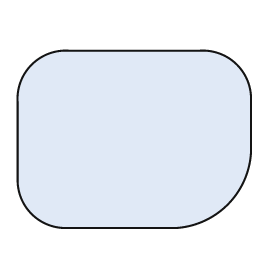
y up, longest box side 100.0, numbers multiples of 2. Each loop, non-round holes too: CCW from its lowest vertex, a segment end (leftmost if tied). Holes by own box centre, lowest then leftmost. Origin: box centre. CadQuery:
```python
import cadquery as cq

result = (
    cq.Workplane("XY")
    .moveTo(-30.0, -38.0)
    .lineTo(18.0, -38.0)
    .threePointArc((40.0, -28.0), (50.0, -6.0))
    .lineTo(50.0, 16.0)
    .threePointArc((44.0, 32.0), (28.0, 38.0))
    .lineTo(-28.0, 38.0)
    .threePointArc((-44.0, 32.0), (-50.0, 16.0))
    .lineTo(-50.0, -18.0)
    .threePointArc((-44.0, -32.0), (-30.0, -38.0))
    .close()
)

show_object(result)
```